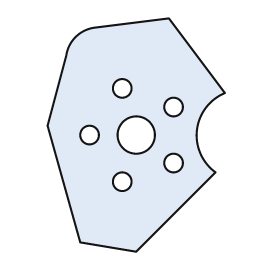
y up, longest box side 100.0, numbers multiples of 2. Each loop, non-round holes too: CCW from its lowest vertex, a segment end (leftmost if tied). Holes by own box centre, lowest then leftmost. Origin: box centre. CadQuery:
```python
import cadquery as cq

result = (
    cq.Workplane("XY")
    .moveTo(0.0, -50.0)
    .lineTo(34.0, -16.0)
    .threePointArc((26.0, 2.0), (38.0, 18.0))
    .lineTo(14.0, 50.0)
    .lineTo(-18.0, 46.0)
    .threePointArc((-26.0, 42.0), (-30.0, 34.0))
    .lineTo(-38.0, 4.0)
    .lineTo(-24.0, -46.0)
    .close()
    .moveTo(-6.0, -20.0)
    .circle(4.0)
    .moveTo(16.0, -12.0)
    .circle(4.0)
    .moveTo(-20.0, 0.0)
    .circle(4.0)
    .moveTo(0.0, 0.0)
    .circle(8.0)
    .moveTo(16.0, 12.0)
    .circle(4.0)
    .moveTo(-6.0, 20.0)
    .circle(4.0)
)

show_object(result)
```